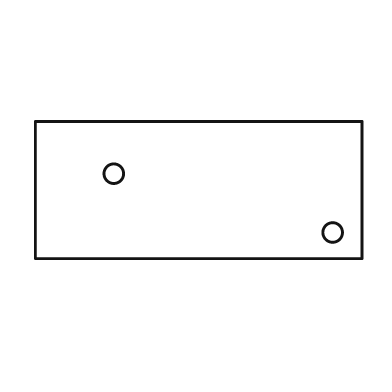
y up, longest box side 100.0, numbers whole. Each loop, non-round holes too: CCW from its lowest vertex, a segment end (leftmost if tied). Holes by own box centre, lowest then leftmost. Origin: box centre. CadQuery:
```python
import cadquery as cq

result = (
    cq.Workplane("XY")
    .moveTo(-50.0, -21.0)
    .lineTo(50.0, -21.0)
    .lineTo(50.0, 21.0)
    .lineTo(-50.0, 21.0)
    .close()
    .moveTo(41.0, -13.0)
    .circle(3.0)
    .moveTo(-26.0, 5.0)
    .circle(3.0)
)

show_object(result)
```